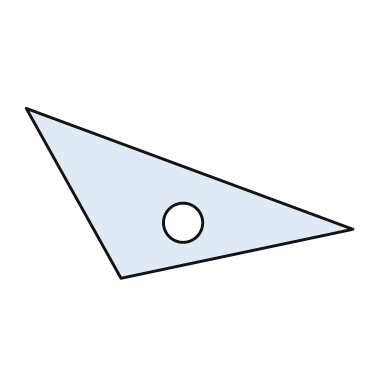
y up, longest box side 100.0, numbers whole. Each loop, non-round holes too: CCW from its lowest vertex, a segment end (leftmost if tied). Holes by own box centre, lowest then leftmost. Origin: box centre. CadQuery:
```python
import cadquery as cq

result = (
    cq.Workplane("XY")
    .moveTo(-21.0, -26.0)
    .lineTo(50.0, -11.0)
    .lineTo(-50.0, 26.0)
    .close()
    .moveTo(-2.0, -9.0)
    .circle(6.0)
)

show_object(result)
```